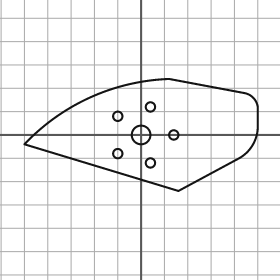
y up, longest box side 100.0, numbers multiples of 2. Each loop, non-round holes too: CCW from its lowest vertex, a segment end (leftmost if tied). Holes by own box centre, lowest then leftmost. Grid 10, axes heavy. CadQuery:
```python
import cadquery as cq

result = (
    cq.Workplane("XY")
    .moveTo(16.0, -24.0)
    .lineTo(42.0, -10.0)
    .threePointArc((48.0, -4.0), (50.0, 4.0))
    .lineTo(50.0, 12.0)
    .threePointArc((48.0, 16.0), (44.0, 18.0))
    .lineTo(12.0, 24.0)
    .threePointArc((-22.0, 16.0), (-50.0, -4.0))
    .close()
    .moveTo(4.0, -12.0)
    .circle(2.0)
    .moveTo(-10.0, -8.0)
    .circle(2.0)
    .moveTo(0.0, 0.0)
    .circle(4.0)
    .moveTo(14.0, 0.0)
    .circle(2.0)
    .moveTo(-10.0, 8.0)
    .circle(2.0)
    .moveTo(4.0, 12.0)
    .circle(2.0)
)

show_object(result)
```